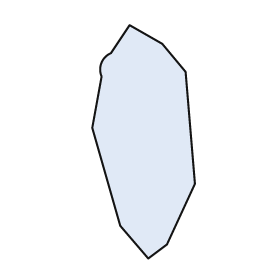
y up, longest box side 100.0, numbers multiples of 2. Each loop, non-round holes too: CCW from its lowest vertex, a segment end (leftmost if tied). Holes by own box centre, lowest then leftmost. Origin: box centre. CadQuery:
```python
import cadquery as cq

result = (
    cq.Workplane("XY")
    .moveTo(2.0, -50.0)
    .lineTo(10.0, -44.0)
    .lineTo(22.0, -18.0)
    .lineTo(18.0, 30.0)
    .lineTo(8.0, 42.0)
    .lineTo(-6.0, 50.0)
    .lineTo(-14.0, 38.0)
    .threePointArc((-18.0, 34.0), (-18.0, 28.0))
    .lineTo(-22.0, 6.0)
    .lineTo(-10.0, -36.0)
    .close()
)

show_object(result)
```